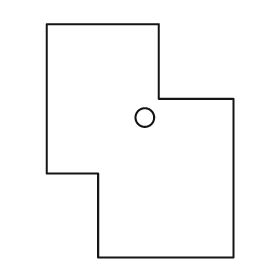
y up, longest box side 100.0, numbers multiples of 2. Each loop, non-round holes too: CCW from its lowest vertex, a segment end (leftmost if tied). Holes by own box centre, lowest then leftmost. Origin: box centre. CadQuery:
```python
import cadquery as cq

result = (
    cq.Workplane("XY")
    .moveTo(-18.0, -50.0)
    .lineTo(40.0, -50.0)
    .lineTo(40.0, 18.0)
    .lineTo(8.0, 18.0)
    .lineTo(8.0, 50.0)
    .lineTo(-40.0, 50.0)
    .lineTo(-40.0, -14.0)
    .lineTo(-18.0, -14.0)
    .close()
    .moveTo(2.0, 10.0)
    .circle(4.0)
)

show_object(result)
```